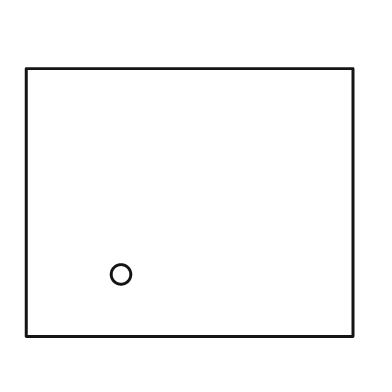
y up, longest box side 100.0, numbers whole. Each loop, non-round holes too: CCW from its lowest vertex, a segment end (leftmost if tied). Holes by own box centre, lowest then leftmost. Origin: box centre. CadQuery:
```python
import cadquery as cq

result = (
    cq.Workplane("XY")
    .moveTo(-50.0, -41.0)
    .lineTo(50.0, -41.0)
    .lineTo(50.0, 41.0)
    .lineTo(-50.0, 41.0)
    .close()
    .moveTo(-21.0, -22.0)
    .circle(3.0)
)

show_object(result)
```